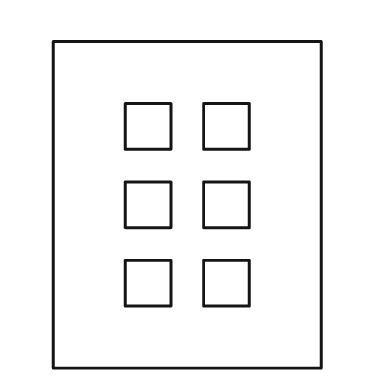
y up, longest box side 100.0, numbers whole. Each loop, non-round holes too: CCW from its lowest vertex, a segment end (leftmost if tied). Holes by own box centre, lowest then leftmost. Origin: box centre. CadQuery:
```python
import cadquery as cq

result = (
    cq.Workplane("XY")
    .moveTo(-41.0, -50.0)
    .lineTo(41.0, -50.0)
    .lineTo(41.0, 50.0)
    .lineTo(-41.0, 50.0)
    .close()
    .moveTo(-19.0, -31.0)
    .lineTo(-5.0, -31.0)
    .lineTo(-5.0, -17.0)
    .lineTo(-19.0, -17.0)
    .close()
    .moveTo(5.0, -31.0)
    .lineTo(19.0, -31.0)
    .lineTo(19.0, -17.0)
    .lineTo(5.0, -17.0)
    .close()
    .moveTo(-19.0, -7.0)
    .lineTo(-5.0, -7.0)
    .lineTo(-5.0, 7.0)
    .lineTo(-19.0, 7.0)
    .close()
    .moveTo(5.0, -7.0)
    .lineTo(19.0, -7.0)
    .lineTo(19.0, 7.0)
    .lineTo(5.0, 7.0)
    .close()
    .moveTo(-19.0, 17.0)
    .lineTo(-5.0, 17.0)
    .lineTo(-5.0, 31.0)
    .lineTo(-19.0, 31.0)
    .close()
    .moveTo(5.0, 17.0)
    .lineTo(19.0, 17.0)
    .lineTo(19.0, 31.0)
    .lineTo(5.0, 31.0)
    .close()
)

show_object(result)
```